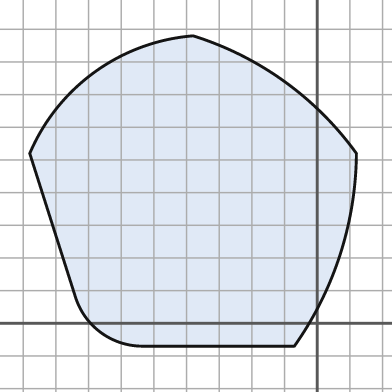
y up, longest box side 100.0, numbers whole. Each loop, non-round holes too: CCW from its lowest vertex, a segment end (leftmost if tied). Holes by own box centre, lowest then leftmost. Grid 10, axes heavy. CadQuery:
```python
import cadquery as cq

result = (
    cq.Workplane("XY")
    .moveTo(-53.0, -7.0)
    .lineTo(-7.0, -7.0)
    .threePointArc((7.0, 21.0), (12.0, 52.0))
    .threePointArc((-10.0, 74.0), (-38.0, 88.0))
    .threePointArc((-68.0, 77.0), (-88.0, 52.0))
    .lineTo(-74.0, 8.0)
    .threePointArc((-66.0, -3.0), (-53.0, -7.0))
    .close()
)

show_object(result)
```